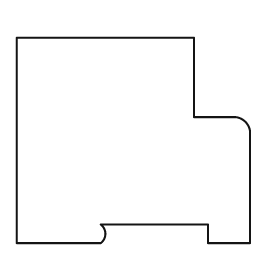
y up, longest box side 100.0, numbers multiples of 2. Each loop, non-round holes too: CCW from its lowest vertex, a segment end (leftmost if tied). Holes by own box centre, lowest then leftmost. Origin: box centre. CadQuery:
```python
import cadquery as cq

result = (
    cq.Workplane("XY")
    .moveTo(-50.0, -44.0)
    .lineTo(-14.0, -44.0)
    .threePointArc((-12.0, -40.0), (-14.0, -36.0))
    .lineTo(32.0, -36.0)
    .lineTo(32.0, -44.0)
    .lineTo(50.0, -44.0)
    .lineTo(50.0, 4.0)
    .threePointArc((48.0, 8.0), (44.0, 10.0))
    .lineTo(26.0, 10.0)
    .lineTo(26.0, 44.0)
    .lineTo(-50.0, 44.0)
    .close()
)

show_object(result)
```